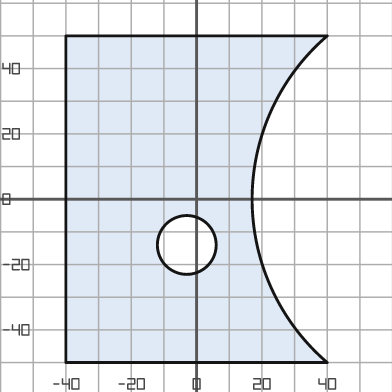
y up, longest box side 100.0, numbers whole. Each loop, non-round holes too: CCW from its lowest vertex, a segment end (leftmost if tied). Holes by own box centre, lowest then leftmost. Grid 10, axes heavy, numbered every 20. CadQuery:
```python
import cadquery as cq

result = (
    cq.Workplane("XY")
    .moveTo(-40.0, -50.0)
    .lineTo(40.0, -50.0)
    .threePointArc((17.0, 0.0), (40.0, 50.0))
    .lineTo(-40.0, 50.0)
    .close()
    .moveTo(-3.0, -14.0)
    .circle(9.0)
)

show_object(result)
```